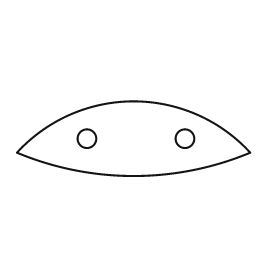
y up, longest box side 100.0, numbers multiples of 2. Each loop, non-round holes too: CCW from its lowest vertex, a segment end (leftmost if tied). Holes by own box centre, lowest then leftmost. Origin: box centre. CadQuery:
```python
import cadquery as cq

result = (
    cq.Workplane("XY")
    .moveTo(-50.0, -6.0)
    .threePointArc((0.0, -16.0), (50.0, -6.0))
    .threePointArc((0.0, 16.0), (-50.0, -6.0))
    .close()
    .moveTo(-20.0, 0.0)
    .circle(4.0)
    .moveTo(22.0, 0.0)
    .circle(4.0)
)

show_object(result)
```